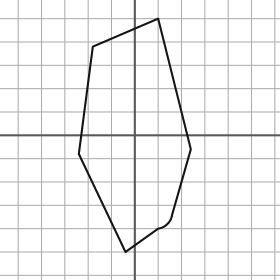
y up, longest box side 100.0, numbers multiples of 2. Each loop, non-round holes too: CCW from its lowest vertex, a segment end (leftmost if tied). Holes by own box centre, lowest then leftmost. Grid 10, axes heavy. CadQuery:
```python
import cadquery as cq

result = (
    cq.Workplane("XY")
    .moveTo(-4.0, -50.0)
    .lineTo(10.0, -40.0)
    .threePointArc((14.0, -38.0), (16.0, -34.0))
    .lineTo(24.0, -6.0)
    .lineTo(10.0, 50.0)
    .lineTo(-18.0, 38.0)
    .lineTo(-24.0, -8.0)
    .close()
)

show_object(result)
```